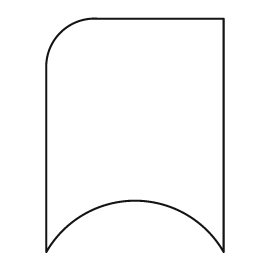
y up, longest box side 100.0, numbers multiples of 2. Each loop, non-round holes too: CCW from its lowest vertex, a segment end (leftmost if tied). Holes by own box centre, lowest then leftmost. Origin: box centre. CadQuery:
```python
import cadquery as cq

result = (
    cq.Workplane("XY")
    .moveTo(-38.0, -50.0)
    .threePointArc((0.0, -28.0), (38.0, -50.0))
    .lineTo(38.0, 50.0)
    .lineTo(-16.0, 50.0)
    .threePointArc((-32.0, 44.0), (-38.0, 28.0))
    .close()
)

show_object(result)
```